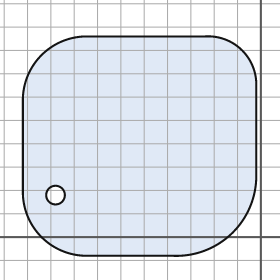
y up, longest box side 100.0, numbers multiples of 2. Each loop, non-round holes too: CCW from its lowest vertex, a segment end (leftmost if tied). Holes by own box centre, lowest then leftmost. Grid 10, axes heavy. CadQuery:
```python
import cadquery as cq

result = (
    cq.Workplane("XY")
    .moveTo(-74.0, -8.0)
    .lineTo(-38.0, -8.0)
    .threePointArc((-12.0, 2.0), (-2.0, 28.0))
    .lineTo(-2.0, 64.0)
    .threePointArc((-8.0, 80.0), (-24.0, 86.0))
    .lineTo(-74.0, 86.0)
    .threePointArc((-94.0, 78.0), (-102.0, 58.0))
    .lineTo(-102.0, 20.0)
    .threePointArc((-94.0, 0.0), (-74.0, -8.0))
    .close()
    .moveTo(-88.0, 18.0)
    .circle(4.0)
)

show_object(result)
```